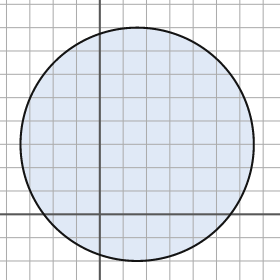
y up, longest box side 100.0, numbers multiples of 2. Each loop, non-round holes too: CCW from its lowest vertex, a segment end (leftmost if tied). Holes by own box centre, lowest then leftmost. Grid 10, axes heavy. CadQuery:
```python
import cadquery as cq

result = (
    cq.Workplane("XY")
    .moveTo(16.0, 30.0)
    .circle(50.0)
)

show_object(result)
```